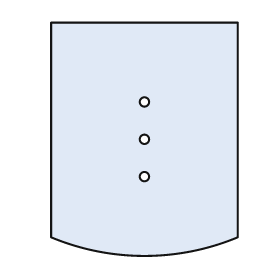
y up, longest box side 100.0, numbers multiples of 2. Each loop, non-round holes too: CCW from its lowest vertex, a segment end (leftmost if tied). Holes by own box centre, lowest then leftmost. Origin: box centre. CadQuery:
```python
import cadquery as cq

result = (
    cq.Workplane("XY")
    .moveTo(-40.0, -42.0)
    .threePointArc((0.0, -50.0), (40.0, -42.0))
    .lineTo(40.0, 50.0)
    .lineTo(-40.0, 50.0)
    .close()
    .moveTo(0.0, -16.0)
    .circle(2.0)
    .moveTo(0.0, 0.0)
    .circle(2.0)
    .moveTo(0.0, 16.0)
    .circle(2.0)
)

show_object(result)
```